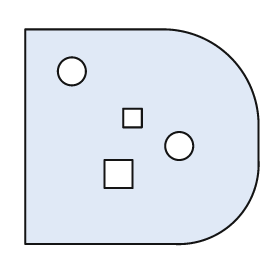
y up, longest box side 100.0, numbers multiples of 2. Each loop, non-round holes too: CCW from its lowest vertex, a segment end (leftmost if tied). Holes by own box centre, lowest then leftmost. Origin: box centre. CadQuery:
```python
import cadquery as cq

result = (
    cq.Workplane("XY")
    .moveTo(-50.0, -46.0)
    .lineTo(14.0, -46.0)
    .threePointArc((40.0, -36.0), (50.0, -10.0))
    .lineTo(50.0, 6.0)
    .threePointArc((38.0, 34.0), (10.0, 46.0))
    .lineTo(-50.0, 46.0)
    .close()
    .moveTo(-16.0, -22.0)
    .lineTo(-4.0, -22.0)
    .lineTo(-4.0, -10.0)
    .lineTo(-16.0, -10.0)
    .close()
    .moveTo(16.0, -4.0)
    .circle(6.0)
    .moveTo(-8.0, 4.0)
    .lineTo(0.0, 4.0)
    .lineTo(0.0, 12.0)
    .lineTo(-8.0, 12.0)
    .close()
    .moveTo(-30.0, 28.0)
    .circle(6.0)
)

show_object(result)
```